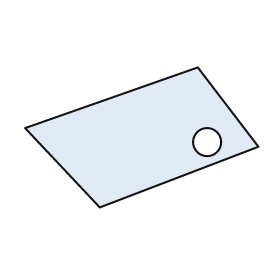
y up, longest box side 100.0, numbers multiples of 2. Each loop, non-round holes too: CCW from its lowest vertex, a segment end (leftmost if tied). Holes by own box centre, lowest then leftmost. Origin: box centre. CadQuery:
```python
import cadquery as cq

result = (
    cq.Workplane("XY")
    .moveTo(-18.0, -30.0)
    .lineTo(50.0, -4.0)
    .lineTo(24.0, 30.0)
    .lineTo(-50.0, 4.0)
    .close()
    .moveTo(28.0, -2.0)
    .circle(6.0)
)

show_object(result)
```